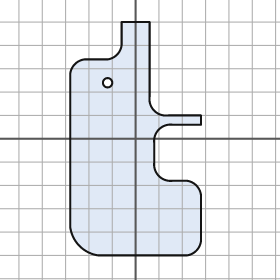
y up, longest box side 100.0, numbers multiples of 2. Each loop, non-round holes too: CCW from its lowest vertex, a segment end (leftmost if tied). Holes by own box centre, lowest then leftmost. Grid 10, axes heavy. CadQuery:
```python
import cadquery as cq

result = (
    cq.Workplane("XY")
    .moveTo(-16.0, -50.0)
    .lineTo(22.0, -50.0)
    .threePointArc((26.0, -48.0), (28.0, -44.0))
    .lineTo(28.0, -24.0)
    .threePointArc((26.0, -20.0), (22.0, -18.0))
    .lineTo(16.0, -18.0)
    .threePointArc((10.0, -16.0), (8.0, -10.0))
    .lineTo(8.0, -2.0)
    .threePointArc((10.0, 4.0), (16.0, 6.0))
    .lineTo(28.0, 6.0)
    .lineTo(28.0, 10.0)
    .lineTo(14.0, 10.0)
    .threePointArc((8.0, 12.0), (6.0, 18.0))
    .lineTo(6.0, 50.0)
    .lineTo(-6.0, 50.0)
    .lineTo(-6.0, 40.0)
    .threePointArc((-8.0, 36.0), (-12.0, 34.0))
    .lineTo(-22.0, 34.0)
    .threePointArc((-26.0, 32.0), (-28.0, 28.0))
    .lineTo(-28.0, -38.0)
    .threePointArc((-24.0, -46.0), (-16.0, -50.0))
    .close()
    .moveTo(-12.0, 24.0)
    .circle(2.0)
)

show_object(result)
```